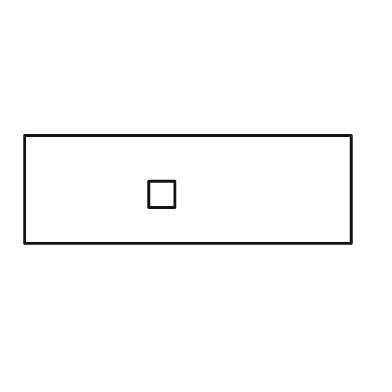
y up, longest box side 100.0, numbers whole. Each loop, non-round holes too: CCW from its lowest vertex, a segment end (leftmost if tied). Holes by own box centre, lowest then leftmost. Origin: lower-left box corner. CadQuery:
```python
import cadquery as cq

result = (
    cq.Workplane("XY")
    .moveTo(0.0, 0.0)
    .lineTo(100.0, 0.0)
    .lineTo(100.0, 33.0)
    .lineTo(0.0, 33.0)
    .close()
    .moveTo(38.0, 11.0)
    .lineTo(46.0, 11.0)
    .lineTo(46.0, 19.0)
    .lineTo(38.0, 19.0)
    .close()
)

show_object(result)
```